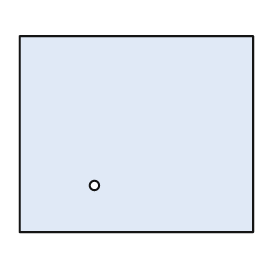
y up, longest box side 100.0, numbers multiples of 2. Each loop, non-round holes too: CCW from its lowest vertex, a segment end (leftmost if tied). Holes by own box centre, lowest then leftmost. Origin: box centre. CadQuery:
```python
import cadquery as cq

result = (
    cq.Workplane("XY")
    .moveTo(-50.0, -42.0)
    .lineTo(50.0, -42.0)
    .lineTo(50.0, 42.0)
    .lineTo(-50.0, 42.0)
    .close()
    .moveTo(-18.0, -22.0)
    .circle(2.0)
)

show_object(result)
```